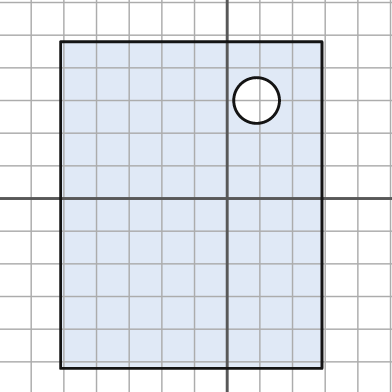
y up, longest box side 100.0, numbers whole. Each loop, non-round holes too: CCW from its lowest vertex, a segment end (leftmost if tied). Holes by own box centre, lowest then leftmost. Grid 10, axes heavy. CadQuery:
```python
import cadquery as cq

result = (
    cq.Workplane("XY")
    .moveTo(-51.0, -52.0)
    .lineTo(29.0, -52.0)
    .lineTo(29.0, 48.0)
    .lineTo(-51.0, 48.0)
    .close()
    .moveTo(9.0, 30.0)
    .circle(7.0)
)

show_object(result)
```